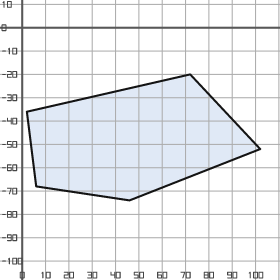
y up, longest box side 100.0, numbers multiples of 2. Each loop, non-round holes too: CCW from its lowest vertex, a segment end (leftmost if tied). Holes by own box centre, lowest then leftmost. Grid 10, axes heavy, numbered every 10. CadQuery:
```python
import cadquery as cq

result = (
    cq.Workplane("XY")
    .moveTo(46.0, -74.0)
    .lineTo(102.0, -52.0)
    .lineTo(72.0, -20.0)
    .lineTo(2.0, -36.0)
    .lineTo(6.0, -68.0)
    .close()
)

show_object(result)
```